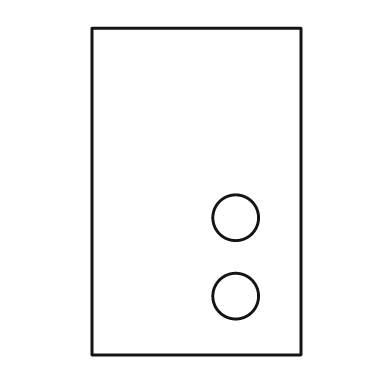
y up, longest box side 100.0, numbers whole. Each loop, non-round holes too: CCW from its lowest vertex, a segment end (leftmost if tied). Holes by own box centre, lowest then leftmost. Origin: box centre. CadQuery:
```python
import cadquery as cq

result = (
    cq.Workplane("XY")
    .moveTo(-32.0, -50.0)
    .lineTo(32.0, -50.0)
    .lineTo(32.0, 50.0)
    .lineTo(-32.0, 50.0)
    .close()
    .moveTo(12.0, -32.0)
    .circle(7.0)
    .moveTo(12.0, -8.0)
    .circle(7.0)
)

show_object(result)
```